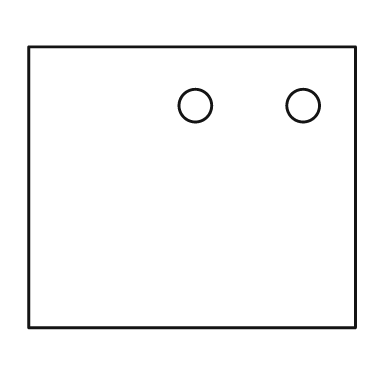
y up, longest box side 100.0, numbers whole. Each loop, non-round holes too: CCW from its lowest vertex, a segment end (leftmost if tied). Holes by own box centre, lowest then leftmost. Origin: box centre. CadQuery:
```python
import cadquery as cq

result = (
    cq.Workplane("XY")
    .moveTo(-50.0, -43.0)
    .lineTo(50.0, -43.0)
    .lineTo(50.0, 43.0)
    .lineTo(-50.0, 43.0)
    .close()
    .moveTo(1.0, 25.0)
    .circle(5.0)
    .moveTo(34.0, 25.0)
    .circle(5.0)
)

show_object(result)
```